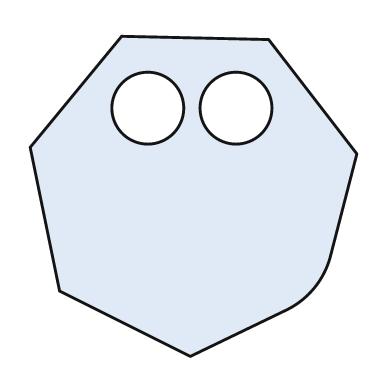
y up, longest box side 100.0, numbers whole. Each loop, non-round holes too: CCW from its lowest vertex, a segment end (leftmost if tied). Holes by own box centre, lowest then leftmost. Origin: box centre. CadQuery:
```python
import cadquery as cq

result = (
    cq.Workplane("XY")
    .moveTo(-1.0, -49.0)
    .lineTo(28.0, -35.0)
    .threePointArc((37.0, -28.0), (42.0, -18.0))
    .lineTo(50.0, 13.0)
    .lineTo(23.0, 48.0)
    .lineTo(-22.0, 49.0)
    .lineTo(-50.0, 15.0)
    .lineTo(-41.0, -29.0)
    .close()
    .moveTo(-14.0, 27.0)
    .circle(11.0)
    .moveTo(13.0, 27.0)
    .circle(11.0)
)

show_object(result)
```